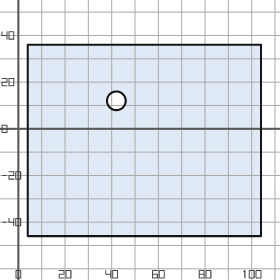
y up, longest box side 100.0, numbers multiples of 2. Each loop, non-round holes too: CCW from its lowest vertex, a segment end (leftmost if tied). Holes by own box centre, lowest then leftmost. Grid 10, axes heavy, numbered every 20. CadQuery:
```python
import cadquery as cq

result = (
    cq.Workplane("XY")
    .moveTo(4.0, -46.0)
    .lineTo(104.0, -46.0)
    .lineTo(104.0, 36.0)
    .lineTo(4.0, 36.0)
    .close()
    .moveTo(42.0, 12.0)
    .circle(4.0)
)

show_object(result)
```